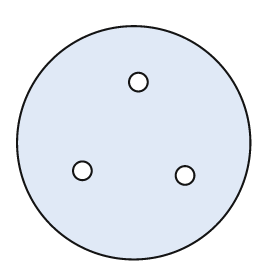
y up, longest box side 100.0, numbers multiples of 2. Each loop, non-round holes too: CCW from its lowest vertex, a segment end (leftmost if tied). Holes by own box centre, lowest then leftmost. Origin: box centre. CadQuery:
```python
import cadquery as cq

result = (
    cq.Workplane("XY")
    .moveTo(0.0, 0.0)
    .circle(50.0)
    .moveTo(22.0, -14.0)
    .circle(4.0)
    .moveTo(-22.0, -12.0)
    .circle(4.0)
    .moveTo(2.0, 26.0)
    .circle(4.0)
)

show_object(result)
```